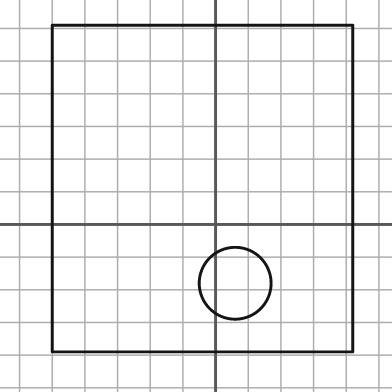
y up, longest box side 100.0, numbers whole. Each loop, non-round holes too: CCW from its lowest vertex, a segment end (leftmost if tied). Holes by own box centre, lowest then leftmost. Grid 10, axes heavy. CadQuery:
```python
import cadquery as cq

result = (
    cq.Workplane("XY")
    .moveTo(-50.0, -39.0)
    .lineTo(42.0, -39.0)
    .lineTo(42.0, 61.0)
    .lineTo(-50.0, 61.0)
    .close()
    .moveTo(6.0, -18.0)
    .circle(11.0)
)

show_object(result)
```